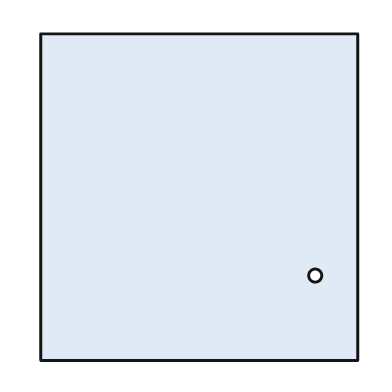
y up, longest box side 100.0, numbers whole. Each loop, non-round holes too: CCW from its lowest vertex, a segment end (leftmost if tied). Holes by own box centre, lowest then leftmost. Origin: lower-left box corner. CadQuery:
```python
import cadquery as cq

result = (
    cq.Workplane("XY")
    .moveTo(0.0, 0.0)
    .lineTo(97.0, 0.0)
    .lineTo(97.0, 100.0)
    .lineTo(0.0, 100.0)
    .close()
    .moveTo(84.0, 26.0)
    .circle(2.0)
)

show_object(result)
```